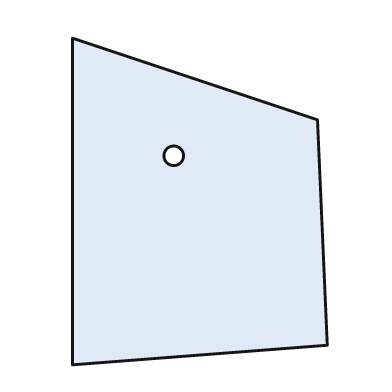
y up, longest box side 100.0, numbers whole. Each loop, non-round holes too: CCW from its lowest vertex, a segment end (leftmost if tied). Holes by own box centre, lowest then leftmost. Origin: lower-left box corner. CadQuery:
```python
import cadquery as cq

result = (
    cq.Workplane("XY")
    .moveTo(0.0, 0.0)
    .lineTo(78.0, 6.0)
    .lineTo(75.0, 75.0)
    .lineTo(0.0, 100.0)
    .close()
    .moveTo(31.0, 64.0)
    .circle(3.0)
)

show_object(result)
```